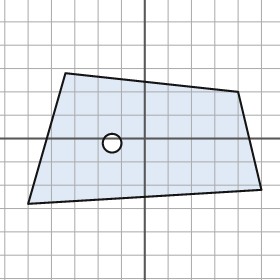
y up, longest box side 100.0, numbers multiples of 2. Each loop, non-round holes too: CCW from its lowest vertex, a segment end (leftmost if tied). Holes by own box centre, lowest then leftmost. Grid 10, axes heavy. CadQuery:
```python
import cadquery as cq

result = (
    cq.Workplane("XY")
    .moveTo(-50.0, -28.0)
    .lineTo(50.0, -22.0)
    .lineTo(40.0, 20.0)
    .lineTo(-34.0, 28.0)
    .close()
    .moveTo(-14.0, -2.0)
    .circle(4.0)
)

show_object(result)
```